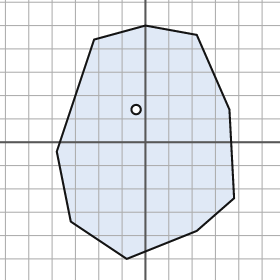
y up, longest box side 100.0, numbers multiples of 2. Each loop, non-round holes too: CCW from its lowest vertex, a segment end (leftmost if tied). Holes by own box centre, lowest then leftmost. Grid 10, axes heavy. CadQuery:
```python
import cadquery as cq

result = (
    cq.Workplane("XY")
    .moveTo(-8.0, -50.0)
    .lineTo(22.0, -38.0)
    .lineTo(38.0, -24.0)
    .lineTo(36.0, 14.0)
    .lineTo(22.0, 46.0)
    .lineTo(0.0, 50.0)
    .lineTo(-22.0, 44.0)
    .lineTo(-38.0, -4.0)
    .lineTo(-32.0, -34.0)
    .close()
    .moveTo(-4.0, 14.0)
    .circle(2.0)
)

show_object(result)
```